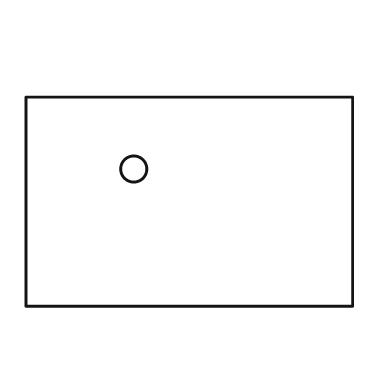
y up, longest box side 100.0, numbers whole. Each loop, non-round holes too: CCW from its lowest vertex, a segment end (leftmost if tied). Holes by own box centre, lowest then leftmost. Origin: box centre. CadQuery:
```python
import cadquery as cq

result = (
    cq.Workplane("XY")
    .moveTo(-50.0, -32.0)
    .lineTo(50.0, -32.0)
    .lineTo(50.0, 32.0)
    .lineTo(-50.0, 32.0)
    .close()
    .moveTo(-17.0, 10.0)
    .circle(4.0)
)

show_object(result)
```